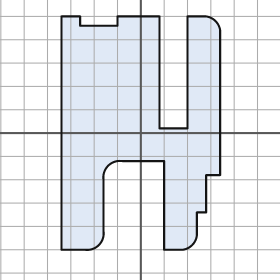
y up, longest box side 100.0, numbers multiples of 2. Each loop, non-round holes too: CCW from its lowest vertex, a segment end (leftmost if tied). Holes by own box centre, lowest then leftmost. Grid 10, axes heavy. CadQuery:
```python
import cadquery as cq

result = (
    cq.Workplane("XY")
    .moveTo(-34.0, -50.0)
    .lineTo(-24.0, -50.0)
    .threePointArc((-18.0, -48.0), (-16.0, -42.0))
    .lineTo(-16.0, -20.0)
    .threePointArc((-14.0, -14.0), (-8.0, -12.0))
    .lineTo(10.0, -12.0)
    .lineTo(10.0, -50.0)
    .lineTo(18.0, -50.0)
    .threePointArc((22.0, -48.0), (24.0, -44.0))
    .lineTo(24.0, -34.0)
    .lineTo(28.0, -34.0)
    .lineTo(28.0, -18.0)
    .lineTo(34.0, -18.0)
    .lineTo(34.0, 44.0)
    .threePointArc((32.0, 48.0), (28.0, 50.0))
    .lineTo(20.0, 50.0)
    .lineTo(20.0, 2.0)
    .lineTo(8.0, 2.0)
    .lineTo(8.0, 50.0)
    .lineTo(-10.0, 50.0)
    .lineTo(-10.0, 46.0)
    .lineTo(-26.0, 46.0)
    .lineTo(-26.0, 50.0)
    .lineTo(-34.0, 50.0)
    .close()
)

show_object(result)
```